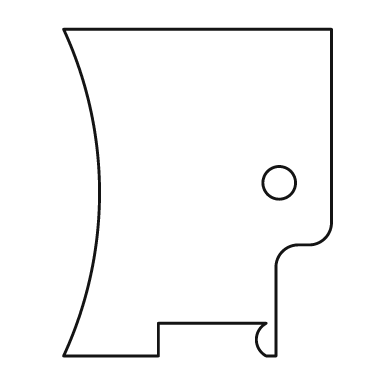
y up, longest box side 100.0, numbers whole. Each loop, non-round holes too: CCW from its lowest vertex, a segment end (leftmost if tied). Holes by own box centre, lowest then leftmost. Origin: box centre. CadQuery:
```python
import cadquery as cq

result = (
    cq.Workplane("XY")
    .moveTo(-41.0, -50.0)
    .lineTo(-12.0, -50.0)
    .lineTo(-12.0, -40.0)
    .lineTo(21.0, -40.0)
    .threePointArc((18.0, -45.0), (21.0, -50.0))
    .lineTo(24.0, -50.0)
    .lineTo(24.0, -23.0)
    .threePointArc((26.0, -18.0), (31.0, -16.0))
    .lineTo(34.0, -16.0)
    .threePointArc((39.0, -14.0), (41.0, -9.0))
    .lineTo(41.0, 50.0)
    .lineTo(-41.0, 50.0)
    .threePointArc((-30.0, 0.0), (-41.0, -50.0))
    .close()
    .moveTo(25.0, 3.0)
    .circle(5.0)
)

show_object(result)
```